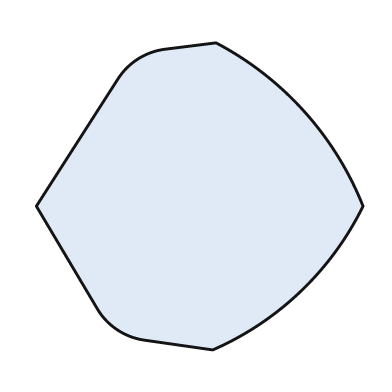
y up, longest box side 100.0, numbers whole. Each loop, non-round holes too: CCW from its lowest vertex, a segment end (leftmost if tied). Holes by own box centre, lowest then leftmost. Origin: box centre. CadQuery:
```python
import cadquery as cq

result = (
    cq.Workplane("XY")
    .moveTo(4.0, -47.0)
    .threePointArc((31.0, -29.0), (50.0, -3.0))
    .threePointArc((32.0, 26.0), (5.0, 47.0))
    .lineTo(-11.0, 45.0)
    .threePointArc((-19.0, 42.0), (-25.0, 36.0))
    .lineTo(-50.0, -3.0)
    .lineTo(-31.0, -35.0)
    .threePointArc((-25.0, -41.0), (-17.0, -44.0))
    .close()
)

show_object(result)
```